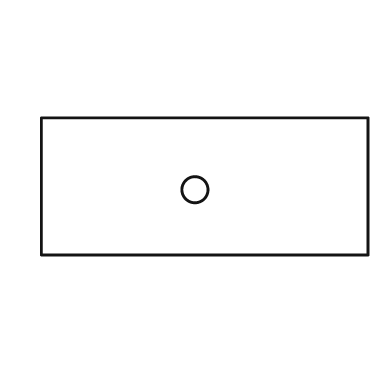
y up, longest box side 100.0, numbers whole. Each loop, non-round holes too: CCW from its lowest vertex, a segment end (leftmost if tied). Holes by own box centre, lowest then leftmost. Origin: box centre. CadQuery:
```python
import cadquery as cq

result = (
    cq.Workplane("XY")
    .moveTo(-50.0, -21.0)
    .lineTo(50.0, -21.0)
    .lineTo(50.0, 21.0)
    .lineTo(-50.0, 21.0)
    .close()
    .moveTo(-3.0, -1.0)
    .circle(4.0)
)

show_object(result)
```